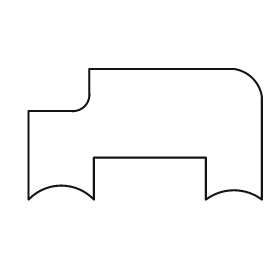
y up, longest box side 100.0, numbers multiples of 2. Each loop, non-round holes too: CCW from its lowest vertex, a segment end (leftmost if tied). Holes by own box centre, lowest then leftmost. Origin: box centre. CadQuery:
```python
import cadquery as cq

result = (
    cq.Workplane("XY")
    .moveTo(-50.0, -28.0)
    .threePointArc((-36.0, -22.0), (-22.0, -28.0))
    .lineTo(-22.0, -10.0)
    .lineTo(26.0, -10.0)
    .lineTo(26.0, -28.0)
    .threePointArc((38.0, -24.0), (50.0, -28.0))
    .lineTo(50.0, 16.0)
    .threePointArc((46.0, 24.0), (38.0, 28.0))
    .lineTo(-24.0, 28.0)
    .lineTo(-24.0, 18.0)
    .threePointArc((-26.0, 12.0), (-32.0, 10.0))
    .lineTo(-50.0, 10.0)
    .close()
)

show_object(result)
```